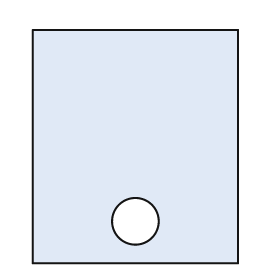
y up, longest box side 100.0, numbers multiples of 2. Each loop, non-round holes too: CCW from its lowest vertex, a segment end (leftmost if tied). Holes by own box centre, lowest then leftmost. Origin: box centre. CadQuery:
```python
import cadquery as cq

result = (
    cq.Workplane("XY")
    .moveTo(-44.0, -50.0)
    .lineTo(44.0, -50.0)
    .lineTo(44.0, 50.0)
    .lineTo(-44.0, 50.0)
    .close()
    .moveTo(0.0, -32.0)
    .circle(10.0)
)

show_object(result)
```